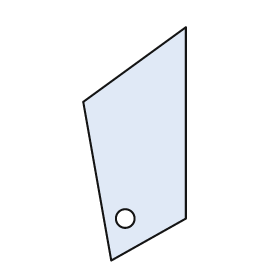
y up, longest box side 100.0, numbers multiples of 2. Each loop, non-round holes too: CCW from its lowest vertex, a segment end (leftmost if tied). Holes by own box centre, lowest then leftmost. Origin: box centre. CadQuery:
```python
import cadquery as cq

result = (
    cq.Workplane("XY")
    .moveTo(-10.0, -50.0)
    .lineTo(22.0, -32.0)
    .lineTo(22.0, 50.0)
    .lineTo(-22.0, 18.0)
    .close()
    .moveTo(-4.0, -32.0)
    .circle(4.0)
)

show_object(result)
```